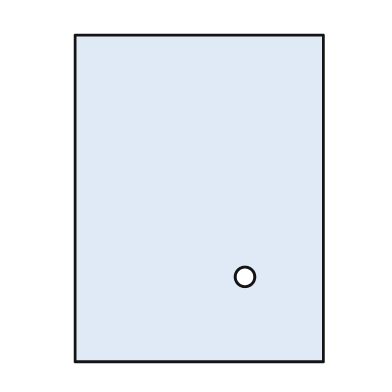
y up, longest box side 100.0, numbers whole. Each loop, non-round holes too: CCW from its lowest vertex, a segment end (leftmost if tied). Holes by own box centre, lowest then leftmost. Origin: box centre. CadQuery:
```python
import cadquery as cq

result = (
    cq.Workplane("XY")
    .moveTo(-38.0, -50.0)
    .lineTo(38.0, -50.0)
    .lineTo(38.0, 50.0)
    .lineTo(-38.0, 50.0)
    .close()
    .moveTo(14.0, -24.0)
    .circle(3.0)
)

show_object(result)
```